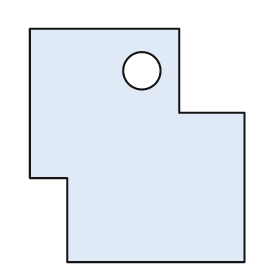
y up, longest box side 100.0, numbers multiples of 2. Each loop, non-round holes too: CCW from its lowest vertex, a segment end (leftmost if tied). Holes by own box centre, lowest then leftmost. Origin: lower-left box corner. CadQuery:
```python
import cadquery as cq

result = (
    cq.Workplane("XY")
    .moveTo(16.0, 0.0)
    .lineTo(92.0, 0.0)
    .lineTo(92.0, 64.0)
    .lineTo(64.0, 64.0)
    .lineTo(64.0, 100.0)
    .lineTo(0.0, 100.0)
    .lineTo(0.0, 36.0)
    .lineTo(16.0, 36.0)
    .close()
    .moveTo(48.0, 82.0)
    .circle(8.0)
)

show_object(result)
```